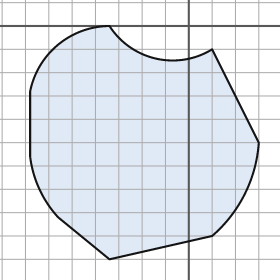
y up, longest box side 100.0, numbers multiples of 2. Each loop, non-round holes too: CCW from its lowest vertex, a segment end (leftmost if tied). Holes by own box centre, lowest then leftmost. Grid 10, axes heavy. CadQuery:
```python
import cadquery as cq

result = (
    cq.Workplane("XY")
    .moveTo(-34.0, -100.0)
    .lineTo(10.0, -90.0)
    .threePointArc((24.0, -72.0), (30.0, -50.0))
    .lineTo(10.0, -10.0)
    .threePointArc((-14.0, -14.0), (-34.0, 0.0))
    .threePointArc((-56.0, -8.0), (-68.0, -28.0))
    .lineTo(-68.0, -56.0)
    .threePointArc((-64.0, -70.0), (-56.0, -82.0))
    .close()
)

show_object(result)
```